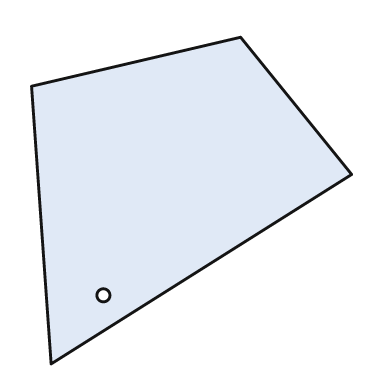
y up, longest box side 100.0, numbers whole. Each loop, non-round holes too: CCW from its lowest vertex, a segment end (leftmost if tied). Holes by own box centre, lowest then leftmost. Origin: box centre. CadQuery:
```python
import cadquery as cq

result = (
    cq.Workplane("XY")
    .moveTo(-43.0, -50.0)
    .lineTo(49.0, 8.0)
    .lineTo(15.0, 50.0)
    .lineTo(-49.0, 35.0)
    .close()
    .moveTo(-27.0, -29.0)
    .circle(2.0)
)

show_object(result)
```